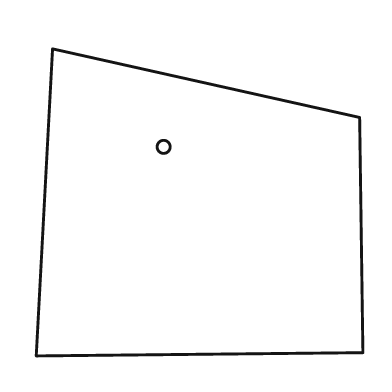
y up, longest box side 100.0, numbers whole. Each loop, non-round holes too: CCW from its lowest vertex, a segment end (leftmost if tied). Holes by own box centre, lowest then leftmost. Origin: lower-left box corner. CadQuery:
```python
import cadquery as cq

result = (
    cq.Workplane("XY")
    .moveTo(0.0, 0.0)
    .lineTo(100.0, 1.0)
    .lineTo(99.0, 73.0)
    .lineTo(5.0, 94.0)
    .close()
    .moveTo(39.0, 64.0)
    .circle(2.0)
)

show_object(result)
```